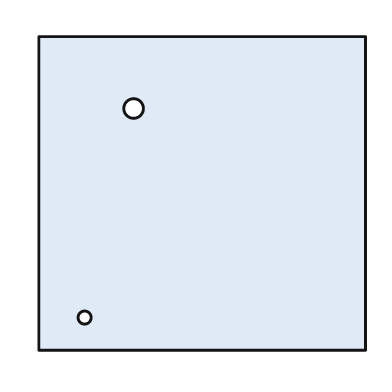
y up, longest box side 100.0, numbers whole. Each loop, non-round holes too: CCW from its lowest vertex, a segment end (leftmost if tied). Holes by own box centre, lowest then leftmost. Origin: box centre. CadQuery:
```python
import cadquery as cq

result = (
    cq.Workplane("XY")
    .moveTo(-50.0, -48.0)
    .lineTo(50.0, -48.0)
    .lineTo(50.0, 48.0)
    .lineTo(-50.0, 48.0)
    .close()
    .moveTo(-36.0, -38.0)
    .circle(2.0)
    .moveTo(-21.0, 26.0)
    .circle(3.0)
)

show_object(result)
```